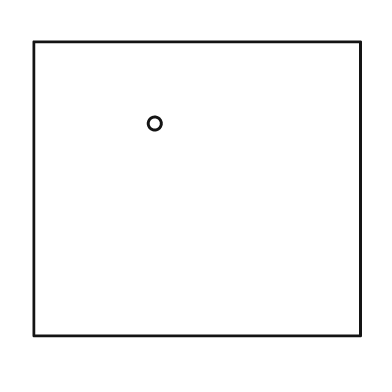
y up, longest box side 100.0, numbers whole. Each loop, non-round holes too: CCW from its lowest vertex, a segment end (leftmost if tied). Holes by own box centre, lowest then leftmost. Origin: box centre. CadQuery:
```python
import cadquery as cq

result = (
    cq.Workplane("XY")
    .moveTo(-50.0, -45.0)
    .lineTo(50.0, -45.0)
    .lineTo(50.0, 45.0)
    .lineTo(-50.0, 45.0)
    .close()
    .moveTo(-13.0, 20.0)
    .circle(2.0)
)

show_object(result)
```